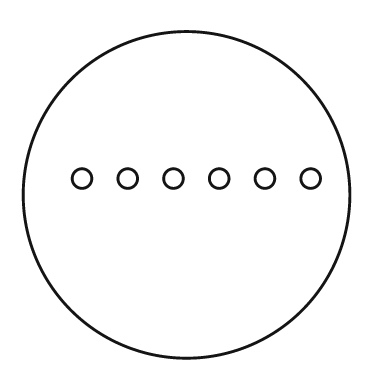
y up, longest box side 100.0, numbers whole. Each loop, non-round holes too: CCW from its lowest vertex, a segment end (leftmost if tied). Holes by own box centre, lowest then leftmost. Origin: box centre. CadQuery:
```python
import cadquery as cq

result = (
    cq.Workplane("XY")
    .moveTo(0.0, 0.0)
    .circle(50.0)
    .moveTo(-32.0, 5.0)
    .circle(3.0)
    .moveTo(-18.0, 5.0)
    .circle(3.0)
    .moveTo(-4.0, 5.0)
    .circle(3.0)
    .moveTo(10.0, 5.0)
    .circle(3.0)
    .moveTo(24.0, 5.0)
    .circle(3.0)
    .moveTo(38.0, 5.0)
    .circle(3.0)
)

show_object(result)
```